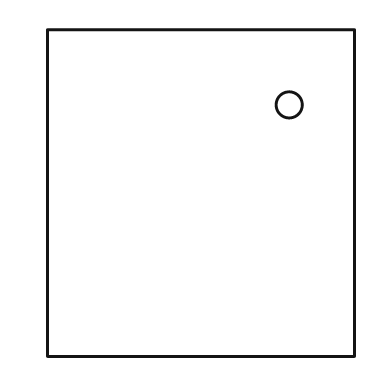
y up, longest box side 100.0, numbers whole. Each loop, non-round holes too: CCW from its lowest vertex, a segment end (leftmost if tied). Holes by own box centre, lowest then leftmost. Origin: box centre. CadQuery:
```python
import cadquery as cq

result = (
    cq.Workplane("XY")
    .moveTo(-47.0, -50.0)
    .lineTo(47.0, -50.0)
    .lineTo(47.0, 50.0)
    .lineTo(-47.0, 50.0)
    .close()
    .moveTo(27.0, 27.0)
    .circle(4.0)
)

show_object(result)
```